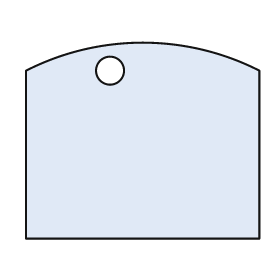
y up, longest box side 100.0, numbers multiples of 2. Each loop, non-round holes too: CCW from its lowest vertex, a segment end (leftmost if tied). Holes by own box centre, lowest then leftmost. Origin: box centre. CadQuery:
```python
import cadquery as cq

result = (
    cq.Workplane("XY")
    .moveTo(-50.0, -42.0)
    .lineTo(50.0, -42.0)
    .lineTo(50.0, 30.0)
    .threePointArc((0.0, 42.0), (-50.0, 30.0))
    .close()
    .moveTo(-14.0, 30.0)
    .circle(6.0)
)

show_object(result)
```